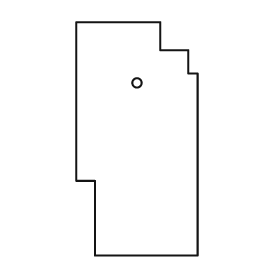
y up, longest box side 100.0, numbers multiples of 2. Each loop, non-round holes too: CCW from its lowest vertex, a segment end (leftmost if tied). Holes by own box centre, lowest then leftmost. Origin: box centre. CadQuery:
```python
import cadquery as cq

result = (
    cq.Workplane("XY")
    .moveTo(-18.0, -50.0)
    .lineTo(26.0, -50.0)
    .lineTo(26.0, 28.0)
    .lineTo(22.0, 28.0)
    .lineTo(22.0, 38.0)
    .lineTo(10.0, 38.0)
    .lineTo(10.0, 50.0)
    .lineTo(-26.0, 50.0)
    .lineTo(-26.0, -18.0)
    .lineTo(-18.0, -18.0)
    .close()
    .moveTo(0.0, 24.0)
    .circle(2.0)
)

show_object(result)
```